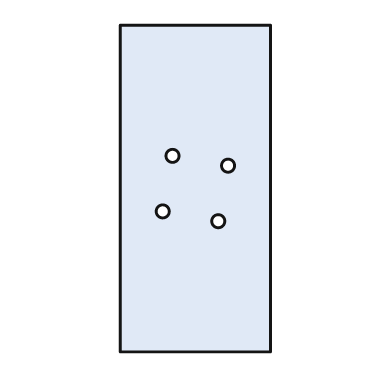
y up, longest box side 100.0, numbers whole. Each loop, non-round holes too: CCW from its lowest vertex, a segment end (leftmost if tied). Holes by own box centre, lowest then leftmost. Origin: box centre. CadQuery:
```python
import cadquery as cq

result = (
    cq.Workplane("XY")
    .moveTo(-23.0, -50.0)
    .lineTo(23.0, -50.0)
    .lineTo(23.0, 50.0)
    .lineTo(-23.0, 50.0)
    .close()
    .moveTo(7.0, -10.0)
    .circle(2.0)
    .moveTo(-10.0, -7.0)
    .circle(2.0)
    .moveTo(10.0, 7.0)
    .circle(2.0)
    .moveTo(-7.0, 10.0)
    .circle(2.0)
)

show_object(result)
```